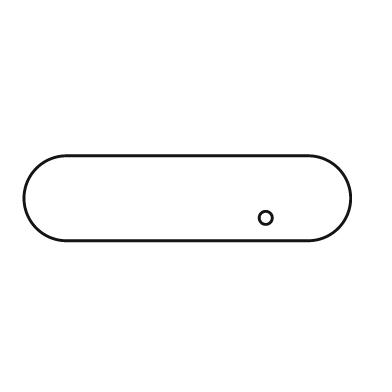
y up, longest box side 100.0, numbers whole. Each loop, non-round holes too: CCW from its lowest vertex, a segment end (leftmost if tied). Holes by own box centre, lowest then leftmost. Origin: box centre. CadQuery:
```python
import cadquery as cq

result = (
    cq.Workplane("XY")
    .moveTo(-37.0, -13.0)
    .lineTo(37.0, -13.0)
    .threePointArc((50.0, 0.0), (37.0, 13.0))
    .lineTo(-37.0, 13.0)
    .threePointArc((-50.0, 0.0), (-37.0, -13.0))
    .close()
    .moveTo(24.0, -6.0)
    .circle(2.0)
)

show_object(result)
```